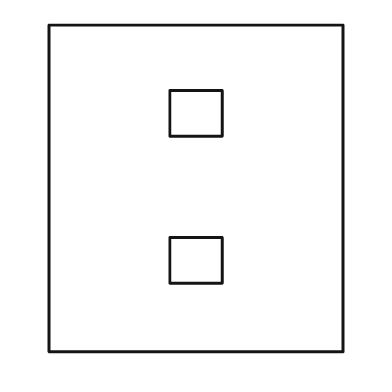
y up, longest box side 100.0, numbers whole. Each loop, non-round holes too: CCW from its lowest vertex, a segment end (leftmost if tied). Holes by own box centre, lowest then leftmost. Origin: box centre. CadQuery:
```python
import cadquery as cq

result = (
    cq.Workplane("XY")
    .moveTo(-45.0, -50.0)
    .lineTo(45.0, -50.0)
    .lineTo(45.0, 50.0)
    .lineTo(-45.0, 50.0)
    .close()
    .moveTo(-8.0, -29.0)
    .lineTo(8.0, -29.0)
    .lineTo(8.0, -15.0)
    .lineTo(-8.0, -15.0)
    .close()
    .moveTo(-8.0, 16.0)
    .lineTo(8.0, 16.0)
    .lineTo(8.0, 30.0)
    .lineTo(-8.0, 30.0)
    .close()
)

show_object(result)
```